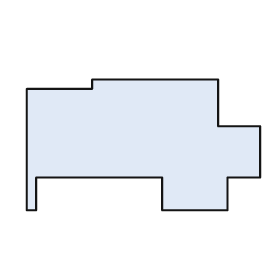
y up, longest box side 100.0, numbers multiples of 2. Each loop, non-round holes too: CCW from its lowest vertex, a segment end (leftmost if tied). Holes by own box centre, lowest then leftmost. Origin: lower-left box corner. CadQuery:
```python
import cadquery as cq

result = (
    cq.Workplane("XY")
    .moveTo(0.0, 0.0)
    .lineTo(4.0, 0.0)
    .lineTo(4.0, 14.0)
    .lineTo(58.0, 14.0)
    .lineTo(58.0, 0.0)
    .lineTo(86.0, 0.0)
    .lineTo(86.0, 14.0)
    .lineTo(100.0, 14.0)
    .lineTo(100.0, 36.0)
    .lineTo(82.0, 36.0)
    .lineTo(82.0, 56.0)
    .lineTo(28.0, 56.0)
    .lineTo(28.0, 52.0)
    .lineTo(0.0, 52.0)
    .close()
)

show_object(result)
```